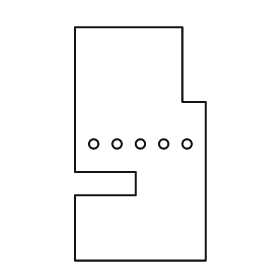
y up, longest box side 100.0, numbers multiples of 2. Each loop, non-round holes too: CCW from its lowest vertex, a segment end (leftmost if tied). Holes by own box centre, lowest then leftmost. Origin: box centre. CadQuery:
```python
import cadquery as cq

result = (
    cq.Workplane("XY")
    .moveTo(-28.0, -50.0)
    .lineTo(28.0, -50.0)
    .lineTo(28.0, 18.0)
    .lineTo(18.0, 18.0)
    .lineTo(18.0, 50.0)
    .lineTo(-28.0, 50.0)
    .lineTo(-28.0, -12.0)
    .lineTo(-2.0, -12.0)
    .lineTo(-2.0, -22.0)
    .lineTo(-28.0, -22.0)
    .close()
    .moveTo(-20.0, 0.0)
    .circle(2.0)
    .moveTo(-10.0, 0.0)
    .circle(2.0)
    .moveTo(0.0, 0.0)
    .circle(2.0)
    .moveTo(10.0, 0.0)
    .circle(2.0)
    .moveTo(20.0, 0.0)
    .circle(2.0)
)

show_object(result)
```